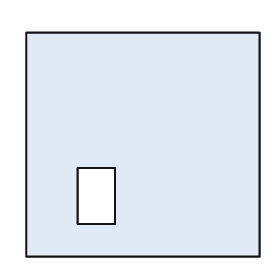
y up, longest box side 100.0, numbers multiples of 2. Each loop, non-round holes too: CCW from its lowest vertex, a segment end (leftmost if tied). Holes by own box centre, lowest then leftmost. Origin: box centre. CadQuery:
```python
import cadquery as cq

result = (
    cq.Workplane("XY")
    .moveTo(-50.0, -48.0)
    .lineTo(50.0, -48.0)
    .lineTo(50.0, 48.0)
    .lineTo(-50.0, 48.0)
    .close()
    .moveTo(-28.0, -34.0)
    .lineTo(-12.0, -34.0)
    .lineTo(-12.0, -10.0)
    .lineTo(-28.0, -10.0)
    .close()
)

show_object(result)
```